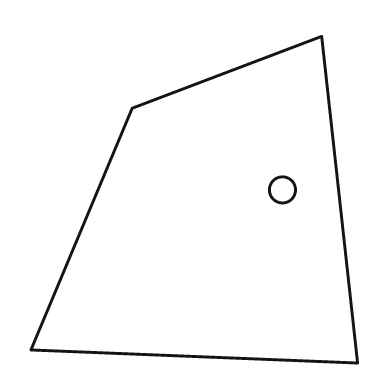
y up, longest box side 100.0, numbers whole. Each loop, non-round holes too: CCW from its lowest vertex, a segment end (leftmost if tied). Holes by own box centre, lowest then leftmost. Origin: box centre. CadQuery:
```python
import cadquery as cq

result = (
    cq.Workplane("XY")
    .moveTo(50.0, -50.0)
    .lineTo(39.0, 50.0)
    .lineTo(-19.0, 28.0)
    .lineTo(-50.0, -46.0)
    .close()
    .moveTo(27.0, 3.0)
    .circle(4.0)
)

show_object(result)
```